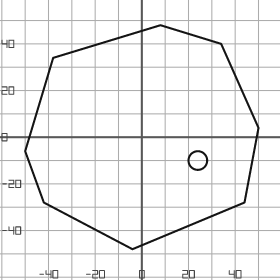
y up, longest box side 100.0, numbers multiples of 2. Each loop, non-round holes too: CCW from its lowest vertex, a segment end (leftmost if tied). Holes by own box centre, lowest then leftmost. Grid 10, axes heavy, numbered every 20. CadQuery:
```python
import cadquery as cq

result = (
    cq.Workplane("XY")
    .moveTo(-4.0, -48.0)
    .lineTo(44.0, -28.0)
    .lineTo(50.0, 4.0)
    .lineTo(34.0, 40.0)
    .lineTo(8.0, 48.0)
    .lineTo(-38.0, 34.0)
    .lineTo(-50.0, -6.0)
    .lineTo(-42.0, -28.0)
    .close()
    .moveTo(24.0, -10.0)
    .circle(4.0)
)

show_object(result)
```